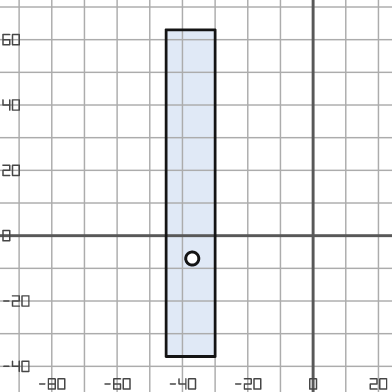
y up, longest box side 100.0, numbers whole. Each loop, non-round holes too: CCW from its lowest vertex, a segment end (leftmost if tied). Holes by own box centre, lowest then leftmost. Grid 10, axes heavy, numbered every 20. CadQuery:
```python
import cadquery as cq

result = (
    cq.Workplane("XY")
    .moveTo(-45.0, -37.0)
    .lineTo(-30.0, -37.0)
    .lineTo(-30.0, 63.0)
    .lineTo(-45.0, 63.0)
    .close()
    .moveTo(-37.0, -7.0)
    .circle(2.0)
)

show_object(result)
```